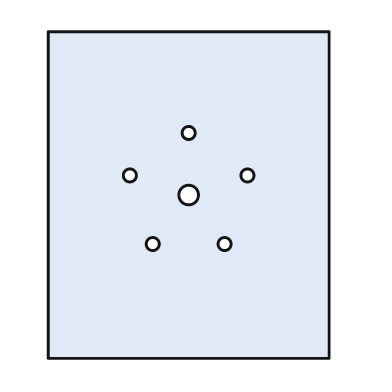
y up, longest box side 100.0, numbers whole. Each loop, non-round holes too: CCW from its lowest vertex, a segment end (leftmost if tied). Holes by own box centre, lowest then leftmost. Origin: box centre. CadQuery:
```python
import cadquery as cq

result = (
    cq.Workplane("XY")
    .moveTo(-43.0, -50.0)
    .lineTo(43.0, -50.0)
    .lineTo(43.0, 50.0)
    .lineTo(-43.0, 50.0)
    .close()
    .moveTo(-11.0, -15.0)
    .circle(2.0)
    .moveTo(11.0, -15.0)
    .circle(2.0)
    .moveTo(0.0, 0.0)
    .circle(3.0)
    .moveTo(-18.0, 6.0)
    .circle(2.0)
    .moveTo(18.0, 6.0)
    .circle(2.0)
    .moveTo(0.0, 19.0)
    .circle(2.0)
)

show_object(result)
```